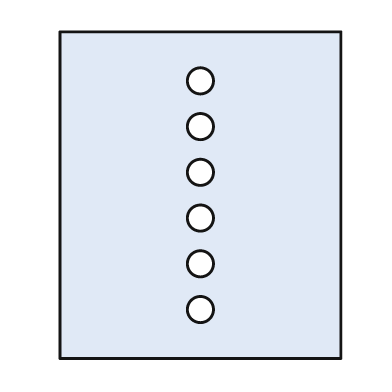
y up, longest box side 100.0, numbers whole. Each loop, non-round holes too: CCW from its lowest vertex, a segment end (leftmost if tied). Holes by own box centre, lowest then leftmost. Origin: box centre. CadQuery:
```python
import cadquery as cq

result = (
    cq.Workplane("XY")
    .moveTo(-43.0, -50.0)
    .lineTo(43.0, -50.0)
    .lineTo(43.0, 50.0)
    .lineTo(-43.0, 50.0)
    .close()
    .moveTo(0.0, -35.0)
    .circle(4.0)
    .moveTo(0.0, -21.0)
    .circle(4.0)
    .moveTo(0.0, -7.0)
    .circle(4.0)
    .moveTo(0.0, 7.0)
    .circle(4.0)
    .moveTo(0.0, 21.0)
    .circle(4.0)
    .moveTo(0.0, 35.0)
    .circle(4.0)
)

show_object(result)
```